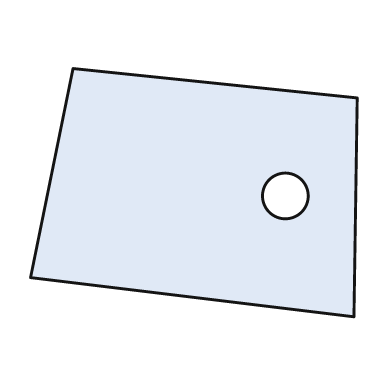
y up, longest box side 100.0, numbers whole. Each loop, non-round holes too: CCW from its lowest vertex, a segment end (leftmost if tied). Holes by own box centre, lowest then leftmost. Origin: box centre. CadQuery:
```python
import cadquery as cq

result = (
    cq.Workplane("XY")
    .moveTo(49.0, -38.0)
    .lineTo(50.0, 29.0)
    .lineTo(-37.0, 38.0)
    .lineTo(-50.0, -26.0)
    .close()
    .moveTo(28.0, -1.0)
    .circle(7.0)
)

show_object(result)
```